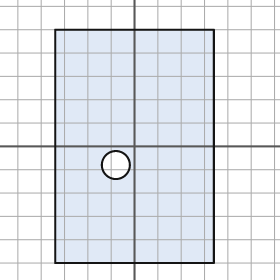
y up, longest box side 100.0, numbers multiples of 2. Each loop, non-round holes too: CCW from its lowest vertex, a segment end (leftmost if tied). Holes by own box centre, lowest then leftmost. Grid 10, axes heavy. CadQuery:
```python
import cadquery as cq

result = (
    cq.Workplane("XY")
    .moveTo(-34.0, -50.0)
    .lineTo(34.0, -50.0)
    .lineTo(34.0, 50.0)
    .lineTo(-34.0, 50.0)
    .close()
    .moveTo(-8.0, -8.0)
    .circle(6.0)
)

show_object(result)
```